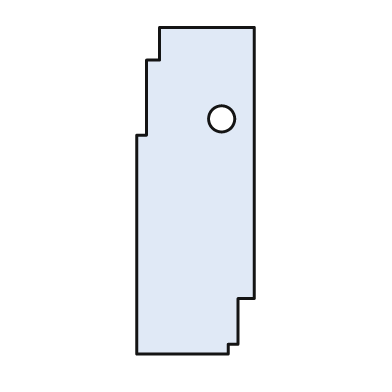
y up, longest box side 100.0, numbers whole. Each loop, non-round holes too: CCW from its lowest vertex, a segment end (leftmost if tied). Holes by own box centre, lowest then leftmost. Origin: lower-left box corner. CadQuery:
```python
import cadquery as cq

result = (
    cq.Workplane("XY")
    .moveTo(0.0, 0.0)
    .lineTo(28.0, 0.0)
    .lineTo(28.0, 3.0)
    .lineTo(31.0, 3.0)
    .lineTo(31.0, 17.0)
    .lineTo(36.0, 17.0)
    .lineTo(36.0, 100.0)
    .lineTo(7.0, 100.0)
    .lineTo(7.0, 90.0)
    .lineTo(3.0, 90.0)
    .lineTo(3.0, 67.0)
    .lineTo(0.0, 67.0)
    .close()
    .moveTo(26.0, 72.0)
    .circle(4.0)
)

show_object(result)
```